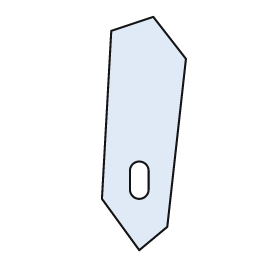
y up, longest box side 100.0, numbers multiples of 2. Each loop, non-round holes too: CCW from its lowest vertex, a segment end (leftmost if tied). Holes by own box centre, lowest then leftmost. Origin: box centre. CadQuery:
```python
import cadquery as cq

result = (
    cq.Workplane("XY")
    .moveTo(-2.0, -50.0)
    .lineTo(10.0, -40.0)
    .lineTo(18.0, 32.0)
    .lineTo(4.0, 50.0)
    .lineTo(-14.0, 44.0)
    .lineTo(-18.0, -28.0)
    .close()
    .moveTo(-6.0, -24.0)
    .threePointArc((-2.0, -28.0), (2.0, -24.0))
    .lineTo(2.0, -16.0)
    .threePointArc((-2.0, -12.0), (-6.0, -16.0))
    .close()
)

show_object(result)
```